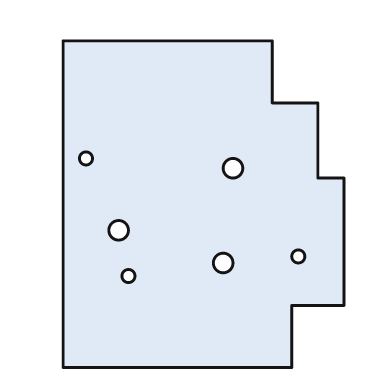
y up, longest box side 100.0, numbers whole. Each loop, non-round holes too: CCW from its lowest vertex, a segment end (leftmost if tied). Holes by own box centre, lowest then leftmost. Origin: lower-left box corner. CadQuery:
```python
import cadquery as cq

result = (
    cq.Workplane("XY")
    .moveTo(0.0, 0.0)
    .lineTo(70.0, 0.0)
    .lineTo(70.0, 19.0)
    .lineTo(86.0, 19.0)
    .lineTo(86.0, 58.0)
    .lineTo(78.0, 58.0)
    .lineTo(78.0, 81.0)
    .lineTo(64.0, 81.0)
    .lineTo(64.0, 100.0)
    .lineTo(0.0, 100.0)
    .close()
    .moveTo(20.0, 28.0)
    .circle(2.0)
    .moveTo(49.0, 32.0)
    .circle(3.0)
    .moveTo(72.0, 34.0)
    .circle(2.0)
    .moveTo(17.0, 42.0)
    .circle(3.0)
    .moveTo(52.0, 61.0)
    .circle(3.0)
    .moveTo(7.0, 64.0)
    .circle(2.0)
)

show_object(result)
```